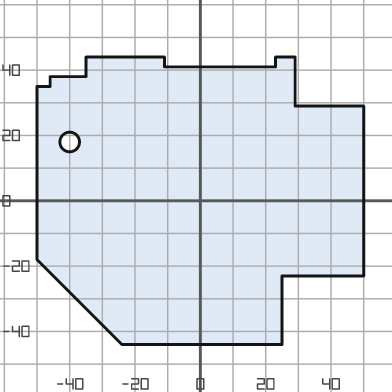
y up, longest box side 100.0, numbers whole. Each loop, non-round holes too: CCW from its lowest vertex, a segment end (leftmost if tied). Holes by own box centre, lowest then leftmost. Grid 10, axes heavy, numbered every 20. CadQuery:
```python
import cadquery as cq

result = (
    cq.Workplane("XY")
    .moveTo(-24.0, -44.0)
    .lineTo(25.0, -44.0)
    .lineTo(25.0, -23.0)
    .lineTo(50.0, -23.0)
    .lineTo(50.0, 29.0)
    .lineTo(29.0, 29.0)
    .lineTo(29.0, 44.0)
    .lineTo(23.0, 44.0)
    .lineTo(23.0, 41.0)
    .lineTo(-11.0, 41.0)
    .lineTo(-11.0, 44.0)
    .lineTo(-35.0, 44.0)
    .lineTo(-35.0, 38.0)
    .lineTo(-46.0, 38.0)
    .lineTo(-46.0, 35.0)
    .lineTo(-50.0, 35.0)
    .lineTo(-50.0, -18.0)
    .close()
    .moveTo(-40.0, 18.0)
    .circle(3.0)
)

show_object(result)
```